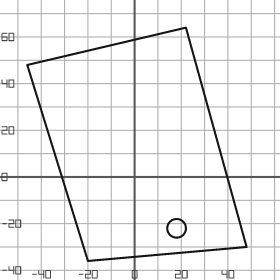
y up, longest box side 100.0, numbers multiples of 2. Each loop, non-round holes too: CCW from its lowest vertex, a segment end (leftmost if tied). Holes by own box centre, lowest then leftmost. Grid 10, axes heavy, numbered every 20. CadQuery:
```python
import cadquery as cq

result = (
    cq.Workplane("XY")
    .moveTo(-20.0, -36.0)
    .lineTo(48.0, -30.0)
    .lineTo(22.0, 64.0)
    .lineTo(-46.0, 48.0)
    .close()
    .moveTo(18.0, -22.0)
    .circle(4.0)
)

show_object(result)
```